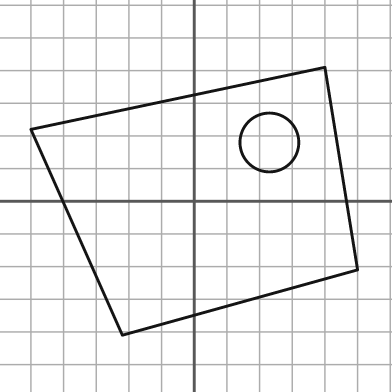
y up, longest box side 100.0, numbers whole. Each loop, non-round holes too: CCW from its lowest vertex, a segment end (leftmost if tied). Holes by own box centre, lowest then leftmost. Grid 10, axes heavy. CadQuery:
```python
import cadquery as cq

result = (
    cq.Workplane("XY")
    .moveTo(-22.0, -41.0)
    .lineTo(50.0, -21.0)
    .lineTo(40.0, 41.0)
    .lineTo(-50.0, 22.0)
    .close()
    .moveTo(23.0, 18.0)
    .circle(9.0)
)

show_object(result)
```